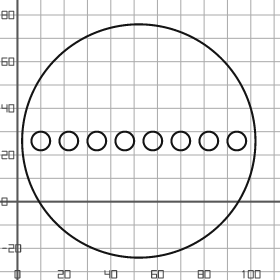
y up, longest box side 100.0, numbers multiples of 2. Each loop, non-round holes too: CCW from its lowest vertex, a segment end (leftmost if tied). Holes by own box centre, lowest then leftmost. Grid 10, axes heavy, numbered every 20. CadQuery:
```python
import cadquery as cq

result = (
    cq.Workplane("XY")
    .moveTo(52.0, 26.0)
    .circle(50.0)
    .moveTo(10.0, 26.0)
    .circle(4.0)
    .moveTo(22.0, 26.0)
    .circle(4.0)
    .moveTo(34.0, 26.0)
    .circle(4.0)
    .moveTo(46.0, 26.0)
    .circle(4.0)
    .moveTo(58.0, 26.0)
    .circle(4.0)
    .moveTo(70.0, 26.0)
    .circle(4.0)
    .moveTo(82.0, 26.0)
    .circle(4.0)
    .moveTo(94.0, 26.0)
    .circle(4.0)
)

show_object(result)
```